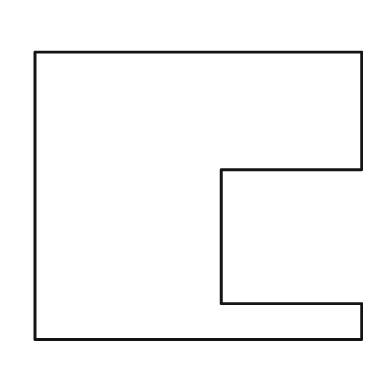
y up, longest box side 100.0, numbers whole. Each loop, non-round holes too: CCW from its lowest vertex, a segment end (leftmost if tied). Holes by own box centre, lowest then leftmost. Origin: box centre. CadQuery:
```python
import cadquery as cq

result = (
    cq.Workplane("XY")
    .moveTo(-50.0, -44.0)
    .lineTo(50.0, -44.0)
    .lineTo(50.0, -33.0)
    .lineTo(7.0, -33.0)
    .lineTo(7.0, 8.0)
    .lineTo(50.0, 8.0)
    .lineTo(50.0, 44.0)
    .lineTo(-50.0, 44.0)
    .close()
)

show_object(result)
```